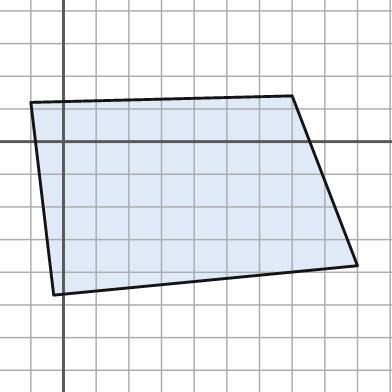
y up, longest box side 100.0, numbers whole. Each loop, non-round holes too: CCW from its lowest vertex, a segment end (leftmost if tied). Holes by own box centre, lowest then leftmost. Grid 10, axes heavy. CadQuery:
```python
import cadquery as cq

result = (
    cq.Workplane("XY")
    .moveTo(-3.0, -47.0)
    .lineTo(90.0, -38.0)
    .lineTo(70.0, 14.0)
    .lineTo(-10.0, 12.0)
    .close()
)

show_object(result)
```